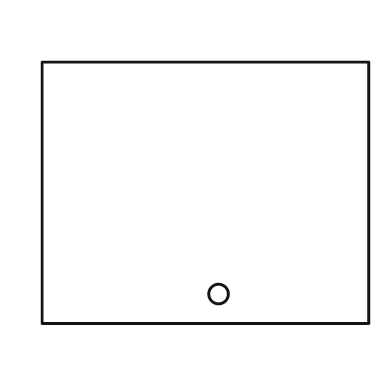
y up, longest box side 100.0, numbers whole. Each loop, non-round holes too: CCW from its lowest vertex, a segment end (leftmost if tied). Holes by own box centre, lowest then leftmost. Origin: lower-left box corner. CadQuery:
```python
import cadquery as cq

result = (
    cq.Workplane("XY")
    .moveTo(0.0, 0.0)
    .lineTo(100.0, 0.0)
    .lineTo(100.0, 80.0)
    .lineTo(0.0, 80.0)
    .close()
    .moveTo(54.0, 9.0)
    .circle(3.0)
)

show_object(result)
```